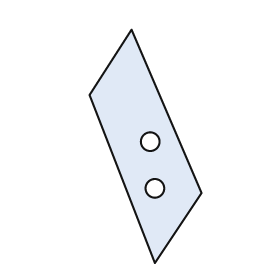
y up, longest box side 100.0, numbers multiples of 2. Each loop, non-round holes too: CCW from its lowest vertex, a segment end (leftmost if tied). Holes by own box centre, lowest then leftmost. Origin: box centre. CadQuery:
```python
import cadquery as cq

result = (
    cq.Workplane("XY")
    .moveTo(4.0, -50.0)
    .lineTo(24.0, -20.0)
    .lineTo(-6.0, 50.0)
    .lineTo(-24.0, 22.0)
    .close()
    .moveTo(4.0, -18.0)
    .circle(4.0)
    .moveTo(2.0, 2.0)
    .circle(4.0)
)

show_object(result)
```